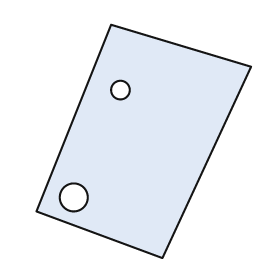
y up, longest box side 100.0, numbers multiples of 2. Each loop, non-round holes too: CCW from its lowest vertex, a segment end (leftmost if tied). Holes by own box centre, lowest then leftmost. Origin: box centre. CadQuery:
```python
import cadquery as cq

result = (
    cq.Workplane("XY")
    .moveTo(8.0, -50.0)
    .lineTo(46.0, 32.0)
    .lineTo(-14.0, 50.0)
    .lineTo(-46.0, -30.0)
    .close()
    .moveTo(-30.0, -24.0)
    .circle(6.0)
    .moveTo(-10.0, 22.0)
    .circle(4.0)
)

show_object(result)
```